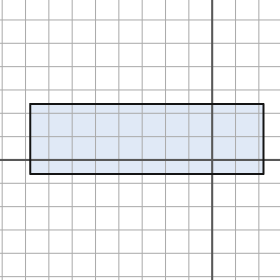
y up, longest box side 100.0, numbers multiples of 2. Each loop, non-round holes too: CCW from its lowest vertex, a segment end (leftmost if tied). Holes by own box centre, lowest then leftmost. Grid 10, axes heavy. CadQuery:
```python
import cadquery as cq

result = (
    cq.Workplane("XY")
    .moveTo(-78.0, -6.0)
    .lineTo(22.0, -6.0)
    .lineTo(22.0, 24.0)
    .lineTo(-78.0, 24.0)
    .close()
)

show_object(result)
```